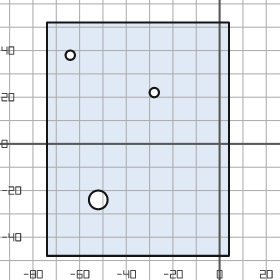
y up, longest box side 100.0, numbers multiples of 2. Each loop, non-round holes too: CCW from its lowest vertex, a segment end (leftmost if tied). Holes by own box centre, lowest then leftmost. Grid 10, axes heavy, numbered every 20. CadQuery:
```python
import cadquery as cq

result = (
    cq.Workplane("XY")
    .moveTo(-74.0, -48.0)
    .lineTo(4.0, -48.0)
    .lineTo(4.0, 52.0)
    .lineTo(-74.0, 52.0)
    .close()
    .moveTo(-52.0, -24.0)
    .circle(4.0)
    .moveTo(-28.0, 22.0)
    .circle(2.0)
    .moveTo(-64.0, 38.0)
    .circle(2.0)
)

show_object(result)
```